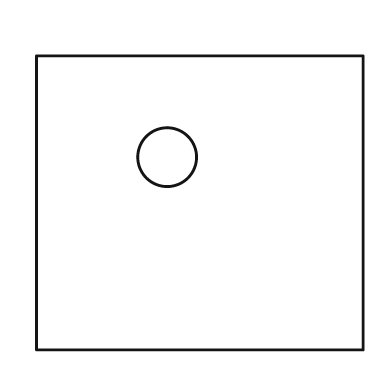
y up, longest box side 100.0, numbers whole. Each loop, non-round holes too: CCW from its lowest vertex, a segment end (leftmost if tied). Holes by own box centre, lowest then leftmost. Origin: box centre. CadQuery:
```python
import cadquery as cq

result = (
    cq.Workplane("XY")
    .moveTo(-50.0, -45.0)
    .lineTo(50.0, -45.0)
    .lineTo(50.0, 45.0)
    .lineTo(-50.0, 45.0)
    .close()
    .moveTo(-10.0, 14.0)
    .circle(9.0)
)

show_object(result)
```